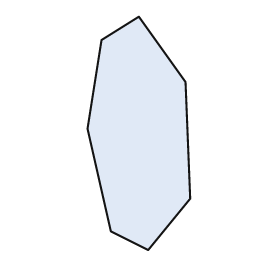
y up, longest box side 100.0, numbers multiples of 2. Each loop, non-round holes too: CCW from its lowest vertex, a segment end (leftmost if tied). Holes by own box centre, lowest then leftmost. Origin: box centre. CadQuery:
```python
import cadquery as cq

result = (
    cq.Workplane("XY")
    .moveTo(4.0, -50.0)
    .lineTo(22.0, -28.0)
    .lineTo(20.0, 22.0)
    .lineTo(0.0, 50.0)
    .lineTo(-16.0, 40.0)
    .lineTo(-22.0, 2.0)
    .lineTo(-12.0, -42.0)
    .close()
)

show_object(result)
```